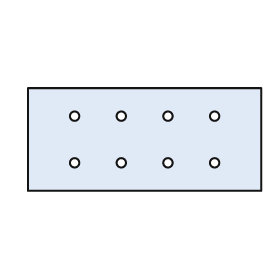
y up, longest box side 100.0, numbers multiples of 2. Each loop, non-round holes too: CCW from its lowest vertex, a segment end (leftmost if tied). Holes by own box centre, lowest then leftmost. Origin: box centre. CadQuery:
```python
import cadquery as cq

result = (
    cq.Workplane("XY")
    .moveTo(-50.0, -22.0)
    .lineTo(50.0, -22.0)
    .lineTo(50.0, 22.0)
    .lineTo(-50.0, 22.0)
    .close()
    .moveTo(-30.0, -10.0)
    .circle(2.0)
    .moveTo(-10.0, -10.0)
    .circle(2.0)
    .moveTo(10.0, -10.0)
    .circle(2.0)
    .moveTo(30.0, -10.0)
    .circle(2.0)
    .moveTo(-30.0, 10.0)
    .circle(2.0)
    .moveTo(-10.0, 10.0)
    .circle(2.0)
    .moveTo(10.0, 10.0)
    .circle(2.0)
    .moveTo(30.0, 10.0)
    .circle(2.0)
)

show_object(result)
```